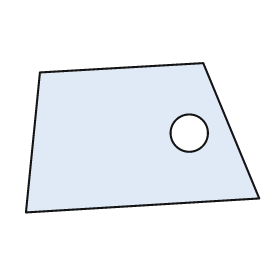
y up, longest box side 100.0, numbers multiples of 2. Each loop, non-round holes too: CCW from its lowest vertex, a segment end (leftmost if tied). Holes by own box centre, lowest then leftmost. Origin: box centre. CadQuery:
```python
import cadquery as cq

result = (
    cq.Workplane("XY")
    .moveTo(-50.0, -32.0)
    .lineTo(50.0, -26.0)
    .lineTo(26.0, 32.0)
    .lineTo(-44.0, 28.0)
    .close()
    .moveTo(20.0, 2.0)
    .circle(8.0)
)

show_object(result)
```